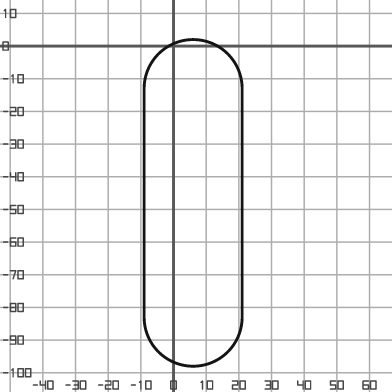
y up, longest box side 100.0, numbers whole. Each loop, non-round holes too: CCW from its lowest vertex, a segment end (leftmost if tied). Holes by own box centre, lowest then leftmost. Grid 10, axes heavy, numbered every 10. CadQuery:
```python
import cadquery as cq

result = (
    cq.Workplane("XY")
    .moveTo(-9.0, -83.0)
    .threePointArc((6.0, -98.0), (21.0, -83.0))
    .lineTo(21.0, -13.0)
    .threePointArc((6.0, 2.0), (-9.0, -13.0))
    .close()
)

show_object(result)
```